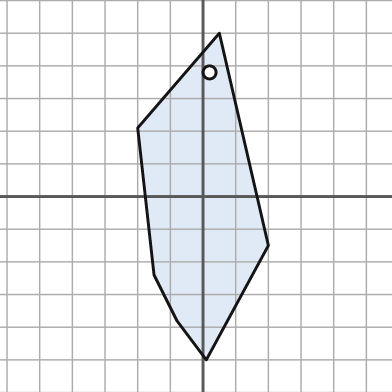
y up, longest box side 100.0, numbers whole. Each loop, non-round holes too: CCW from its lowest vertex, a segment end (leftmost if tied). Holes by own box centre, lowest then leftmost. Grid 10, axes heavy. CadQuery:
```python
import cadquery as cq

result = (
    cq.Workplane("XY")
    .moveTo(1.0, -50.0)
    .lineTo(20.0, -15.0)
    .lineTo(5.0, 50.0)
    .lineTo(-20.0, 21.0)
    .lineTo(-15.0, -24.0)
    .lineTo(-8.0, -38.0)
    .close()
    .moveTo(2.0, 38.0)
    .circle(2.0)
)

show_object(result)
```